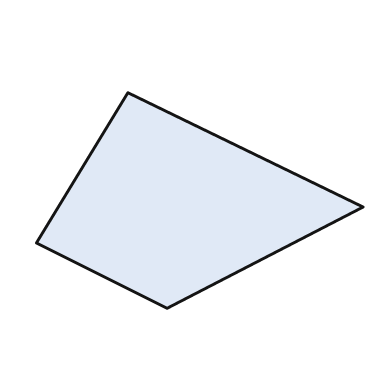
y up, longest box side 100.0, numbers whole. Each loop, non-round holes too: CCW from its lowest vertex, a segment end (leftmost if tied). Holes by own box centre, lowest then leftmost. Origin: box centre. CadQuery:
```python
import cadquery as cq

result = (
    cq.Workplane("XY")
    .moveTo(-10.0, -33.0)
    .lineTo(50.0, -2.0)
    .lineTo(-22.0, 33.0)
    .lineTo(-50.0, -13.0)
    .close()
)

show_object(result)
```